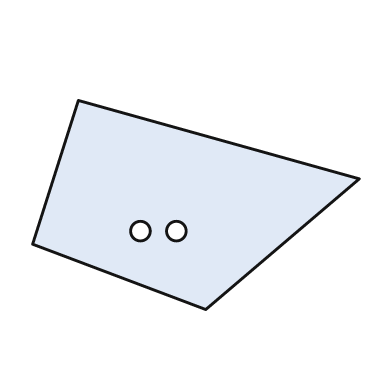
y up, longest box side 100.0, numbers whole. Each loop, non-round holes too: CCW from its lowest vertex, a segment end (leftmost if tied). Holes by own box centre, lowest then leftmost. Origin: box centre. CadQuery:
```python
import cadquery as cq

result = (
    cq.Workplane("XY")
    .moveTo(3.0, -32.0)
    .lineTo(50.0, 8.0)
    .lineTo(-36.0, 32.0)
    .lineTo(-50.0, -12.0)
    .close()
    .moveTo(-17.0, -8.0)
    .circle(3.0)
    .moveTo(-6.0, -8.0)
    .circle(3.0)
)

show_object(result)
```